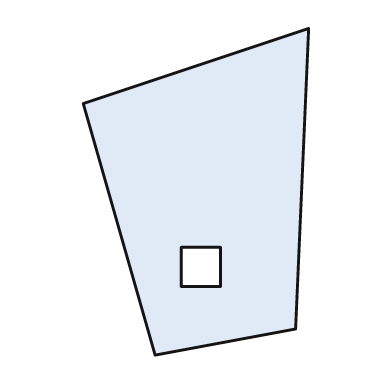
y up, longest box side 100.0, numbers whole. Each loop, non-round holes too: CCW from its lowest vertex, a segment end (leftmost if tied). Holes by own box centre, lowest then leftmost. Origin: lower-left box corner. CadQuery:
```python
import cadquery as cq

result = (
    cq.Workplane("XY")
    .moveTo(22.0, 0.0)
    .lineTo(65.0, 8.0)
    .lineTo(69.0, 100.0)
    .lineTo(0.0, 77.0)
    .close()
    .moveTo(30.0, 21.0)
    .lineTo(42.0, 21.0)
    .lineTo(42.0, 33.0)
    .lineTo(30.0, 33.0)
    .close()
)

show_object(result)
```